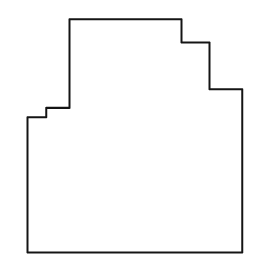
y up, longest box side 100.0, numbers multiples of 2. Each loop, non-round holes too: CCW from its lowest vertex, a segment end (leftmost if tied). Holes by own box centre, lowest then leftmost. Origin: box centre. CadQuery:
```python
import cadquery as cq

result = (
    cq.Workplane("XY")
    .moveTo(-46.0, -50.0)
    .lineTo(46.0, -50.0)
    .lineTo(46.0, 20.0)
    .lineTo(32.0, 20.0)
    .lineTo(32.0, 40.0)
    .lineTo(20.0, 40.0)
    .lineTo(20.0, 50.0)
    .lineTo(-28.0, 50.0)
    .lineTo(-28.0, 12.0)
    .lineTo(-38.0, 12.0)
    .lineTo(-38.0, 8.0)
    .lineTo(-46.0, 8.0)
    .close()
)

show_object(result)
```